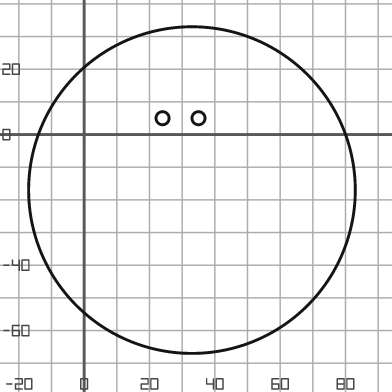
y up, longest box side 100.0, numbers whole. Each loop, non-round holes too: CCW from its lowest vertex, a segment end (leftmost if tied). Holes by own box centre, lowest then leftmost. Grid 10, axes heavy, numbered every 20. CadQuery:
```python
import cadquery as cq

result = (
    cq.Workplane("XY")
    .moveTo(33.0, -17.0)
    .circle(50.0)
    .moveTo(24.0, 5.0)
    .circle(2.0)
    .moveTo(35.0, 5.0)
    .circle(2.0)
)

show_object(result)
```